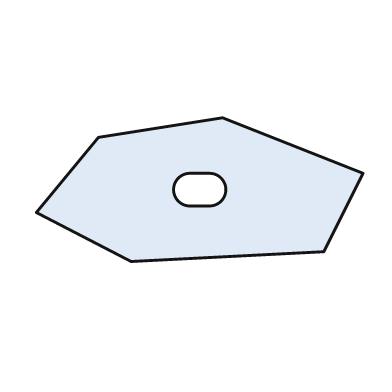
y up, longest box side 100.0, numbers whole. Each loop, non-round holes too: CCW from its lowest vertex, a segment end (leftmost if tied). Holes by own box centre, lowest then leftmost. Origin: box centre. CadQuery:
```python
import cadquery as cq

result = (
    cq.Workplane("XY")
    .moveTo(-21.0, -22.0)
    .lineTo(38.0, -19.0)
    .lineTo(50.0, 5.0)
    .lineTo(7.0, 22.0)
    .lineTo(-31.0, 16.0)
    .lineTo(-50.0, -7.0)
    .close()
    .moveTo(-3.0, -5.0)
    .lineTo(3.0, -5.0)
    .threePointArc((8.0, 0.0), (3.0, 5.0))
    .lineTo(-3.0, 5.0)
    .threePointArc((-8.0, 0.0), (-3.0, -5.0))
    .close()
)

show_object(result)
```